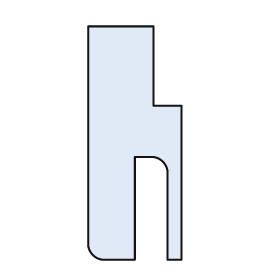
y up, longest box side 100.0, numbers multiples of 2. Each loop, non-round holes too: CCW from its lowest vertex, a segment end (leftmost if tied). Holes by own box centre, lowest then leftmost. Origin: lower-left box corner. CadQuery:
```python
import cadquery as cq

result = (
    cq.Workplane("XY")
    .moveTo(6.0, 0.0)
    .lineTo(20.0, 0.0)
    .lineTo(20.0, 44.0)
    .lineTo(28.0, 44.0)
    .threePointArc((32.0, 42.0), (34.0, 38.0))
    .lineTo(34.0, 0.0)
    .lineTo(40.0, 0.0)
    .lineTo(40.0, 66.0)
    .lineTo(28.0, 66.0)
    .lineTo(28.0, 100.0)
    .lineTo(0.0, 100.0)
    .lineTo(0.0, 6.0)
    .threePointArc((2.0, 2.0), (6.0, 0.0))
    .close()
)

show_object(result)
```